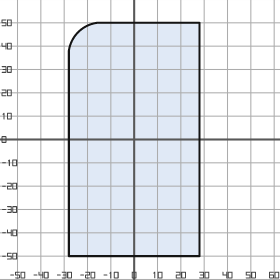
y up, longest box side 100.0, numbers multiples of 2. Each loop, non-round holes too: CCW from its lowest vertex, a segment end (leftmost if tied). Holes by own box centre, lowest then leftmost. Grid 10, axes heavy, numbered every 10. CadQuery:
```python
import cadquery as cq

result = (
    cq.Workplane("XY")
    .moveTo(-28.0, -50.0)
    .lineTo(28.0, -50.0)
    .lineTo(28.0, 50.0)
    .lineTo(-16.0, 50.0)
    .threePointArc((-24.0, 46.0), (-28.0, 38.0))
    .close()
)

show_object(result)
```